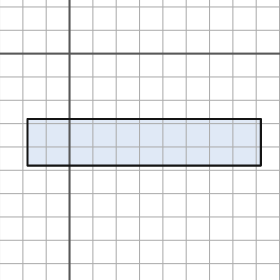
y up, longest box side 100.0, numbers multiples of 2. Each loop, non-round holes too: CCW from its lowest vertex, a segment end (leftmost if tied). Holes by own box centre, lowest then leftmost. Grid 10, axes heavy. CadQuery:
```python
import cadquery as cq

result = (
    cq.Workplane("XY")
    .moveTo(-18.0, -48.0)
    .lineTo(82.0, -48.0)
    .lineTo(82.0, -28.0)
    .lineTo(-18.0, -28.0)
    .close()
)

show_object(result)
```